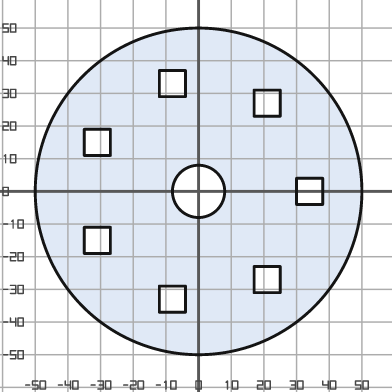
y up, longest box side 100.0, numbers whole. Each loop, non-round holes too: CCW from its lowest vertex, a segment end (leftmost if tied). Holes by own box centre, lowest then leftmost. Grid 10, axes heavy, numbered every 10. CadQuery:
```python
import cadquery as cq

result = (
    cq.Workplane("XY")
    .moveTo(0.0, 0.0)
    .circle(50.0)
    .moveTo(-12.0, -37.0)
    .lineTo(-4.0, -37.0)
    .lineTo(-4.0, -29.0)
    .lineTo(-12.0, -29.0)
    .close()
    .moveTo(17.0, -31.0)
    .lineTo(25.0, -31.0)
    .lineTo(25.0, -23.0)
    .lineTo(17.0, -23.0)
    .close()
    .moveTo(-35.0, -19.0)
    .lineTo(-27.0, -19.0)
    .lineTo(-27.0, -11.0)
    .lineTo(-35.0, -11.0)
    .close()
    .moveTo(0.0, 0.0)
    .circle(8.0)
    .moveTo(30.0, -4.0)
    .lineTo(38.0, -4.0)
    .lineTo(38.0, 4.0)
    .lineTo(30.0, 4.0)
    .close()
    .moveTo(-35.0, 11.0)
    .lineTo(-27.0, 11.0)
    .lineTo(-27.0, 19.0)
    .lineTo(-35.0, 19.0)
    .close()
    .moveTo(17.0, 23.0)
    .lineTo(25.0, 23.0)
    .lineTo(25.0, 31.0)
    .lineTo(17.0, 31.0)
    .close()
    .moveTo(-12.0, 29.0)
    .lineTo(-4.0, 29.0)
    .lineTo(-4.0, 37.0)
    .lineTo(-12.0, 37.0)
    .close()
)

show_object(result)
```